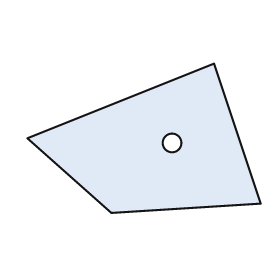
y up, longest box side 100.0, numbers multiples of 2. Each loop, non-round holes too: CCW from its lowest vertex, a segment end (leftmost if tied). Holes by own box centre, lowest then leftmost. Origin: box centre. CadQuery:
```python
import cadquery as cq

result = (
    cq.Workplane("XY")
    .moveTo(-14.0, -32.0)
    .lineTo(50.0, -28.0)
    .lineTo(30.0, 32.0)
    .lineTo(-50.0, 0.0)
    .close()
    .moveTo(12.0, -2.0)
    .circle(4.0)
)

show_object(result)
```